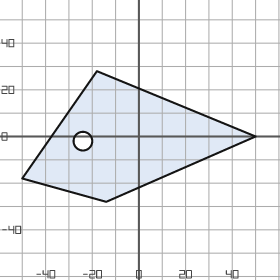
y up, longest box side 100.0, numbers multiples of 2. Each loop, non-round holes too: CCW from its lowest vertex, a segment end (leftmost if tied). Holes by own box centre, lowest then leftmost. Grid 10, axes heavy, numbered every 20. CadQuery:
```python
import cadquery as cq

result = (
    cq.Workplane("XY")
    .moveTo(-14.0, -28.0)
    .lineTo(50.0, 0.0)
    .lineTo(-18.0, 28.0)
    .lineTo(-50.0, -18.0)
    .close()
    .moveTo(-24.0, -2.0)
    .circle(4.0)
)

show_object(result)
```